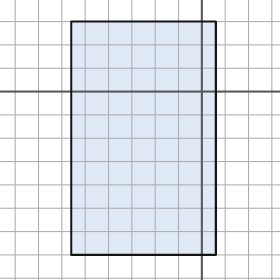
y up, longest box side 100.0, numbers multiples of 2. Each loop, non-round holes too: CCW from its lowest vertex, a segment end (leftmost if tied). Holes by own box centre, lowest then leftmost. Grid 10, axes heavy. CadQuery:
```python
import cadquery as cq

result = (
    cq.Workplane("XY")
    .moveTo(-56.0, -70.0)
    .lineTo(6.0, -70.0)
    .lineTo(6.0, 30.0)
    .lineTo(-56.0, 30.0)
    .close()
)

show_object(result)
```